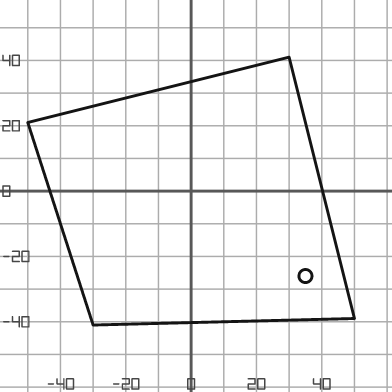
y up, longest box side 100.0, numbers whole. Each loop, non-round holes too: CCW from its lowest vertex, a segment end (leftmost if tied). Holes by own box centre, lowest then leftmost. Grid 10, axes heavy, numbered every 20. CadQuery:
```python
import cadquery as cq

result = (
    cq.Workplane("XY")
    .moveTo(-30.0, -41.0)
    .lineTo(50.0, -39.0)
    .lineTo(30.0, 41.0)
    .lineTo(-50.0, 21.0)
    .close()
    .moveTo(35.0, -26.0)
    .circle(2.0)
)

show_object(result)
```